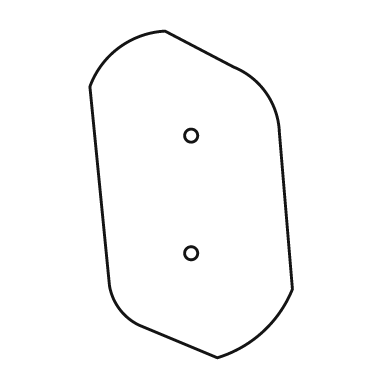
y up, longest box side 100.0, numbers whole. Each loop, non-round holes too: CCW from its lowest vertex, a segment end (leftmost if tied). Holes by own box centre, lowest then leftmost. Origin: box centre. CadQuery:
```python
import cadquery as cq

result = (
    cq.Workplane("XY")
    .moveTo(8.0, -50.0)
    .threePointArc((22.0, -42.0), (31.0, -29.0))
    .lineTo(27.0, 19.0)
    .threePointArc((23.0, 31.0), (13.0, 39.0))
    .lineTo(-8.0, 50.0)
    .threePointArc((-22.0, 45.0), (-31.0, 33.0))
    .lineTo(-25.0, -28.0)
    .threePointArc((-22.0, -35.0), (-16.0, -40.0))
    .close()
    .moveTo(0.0, -18.0)
    .circle(2.0)
    .moveTo(0.0, 18.0)
    .circle(2.0)
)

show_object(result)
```